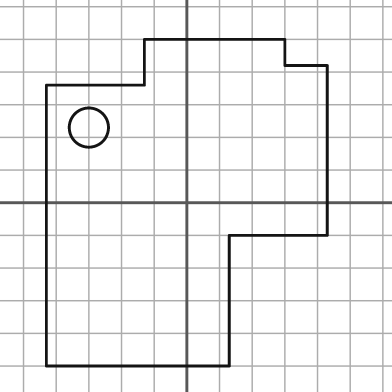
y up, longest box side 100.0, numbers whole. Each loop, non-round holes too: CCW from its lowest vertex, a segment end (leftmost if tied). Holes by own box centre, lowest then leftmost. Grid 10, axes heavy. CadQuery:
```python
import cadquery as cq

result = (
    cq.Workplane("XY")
    .moveTo(-43.0, -50.0)
    .lineTo(13.0, -50.0)
    .lineTo(13.0, -10.0)
    .lineTo(43.0, -10.0)
    .lineTo(43.0, 42.0)
    .lineTo(30.0, 42.0)
    .lineTo(30.0, 50.0)
    .lineTo(-13.0, 50.0)
    .lineTo(-13.0, 36.0)
    .lineTo(-43.0, 36.0)
    .close()
    .moveTo(-30.0, 23.0)
    .circle(6.0)
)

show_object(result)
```